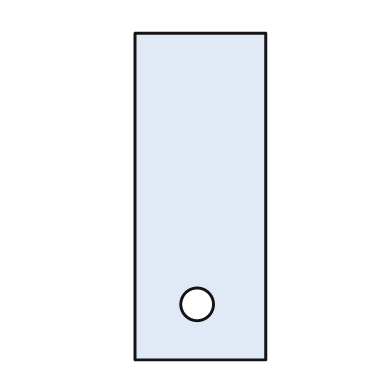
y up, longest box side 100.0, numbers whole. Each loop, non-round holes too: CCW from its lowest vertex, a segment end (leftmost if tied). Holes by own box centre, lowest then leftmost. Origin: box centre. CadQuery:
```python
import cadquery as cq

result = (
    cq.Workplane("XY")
    .moveTo(-20.0, -50.0)
    .lineTo(20.0, -50.0)
    .lineTo(20.0, 50.0)
    .lineTo(-20.0, 50.0)
    .close()
    .moveTo(-1.0, -33.0)
    .circle(5.0)
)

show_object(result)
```